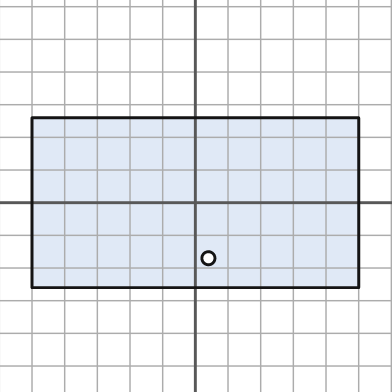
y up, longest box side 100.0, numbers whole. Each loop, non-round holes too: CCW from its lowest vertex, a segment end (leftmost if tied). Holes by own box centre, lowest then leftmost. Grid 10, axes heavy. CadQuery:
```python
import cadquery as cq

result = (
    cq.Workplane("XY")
    .moveTo(-50.0, -26.0)
    .lineTo(50.0, -26.0)
    .lineTo(50.0, 26.0)
    .lineTo(-50.0, 26.0)
    .close()
    .moveTo(4.0, -17.0)
    .circle(2.0)
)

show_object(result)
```